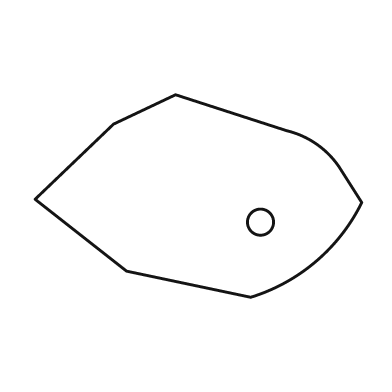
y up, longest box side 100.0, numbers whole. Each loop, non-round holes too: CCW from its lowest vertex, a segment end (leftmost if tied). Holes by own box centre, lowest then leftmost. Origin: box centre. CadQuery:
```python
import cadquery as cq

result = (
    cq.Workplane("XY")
    .moveTo(16.0, -31.0)
    .threePointArc((36.0, -20.0), (50.0, -2.0))
    .lineTo(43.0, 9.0)
    .threePointArc((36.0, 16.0), (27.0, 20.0))
    .lineTo(-7.0, 31.0)
    .lineTo(-26.0, 22.0)
    .lineTo(-50.0, -1.0)
    .lineTo(-22.0, -23.0)
    .close()
    .moveTo(19.0, -8.0)
    .circle(4.0)
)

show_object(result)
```